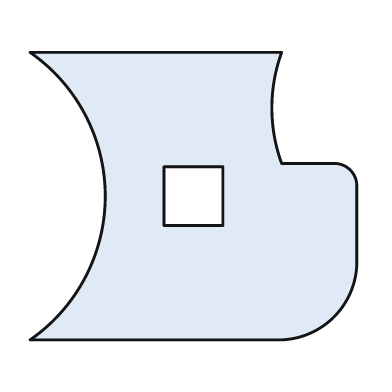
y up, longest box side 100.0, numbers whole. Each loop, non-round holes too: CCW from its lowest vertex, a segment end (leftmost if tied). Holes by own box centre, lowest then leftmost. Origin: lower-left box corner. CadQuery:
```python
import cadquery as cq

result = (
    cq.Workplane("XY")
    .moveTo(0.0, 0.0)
    .lineTo(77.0, 0.0)
    .threePointArc((93.0, 7.0), (100.0, 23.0))
    .lineTo(100.0, 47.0)
    .threePointArc((98.0, 52.0), (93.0, 54.0))
    .lineTo(77.0, 54.0)
    .threePointArc((74.0, 71.0), (77.0, 88.0))
    .lineTo(0.0, 88.0)
    .threePointArc((23.0, 44.0), (0.0, 0.0))
    .close()
    .moveTo(41.0, 35.0)
    .lineTo(59.0, 35.0)
    .lineTo(59.0, 53.0)
    .lineTo(41.0, 53.0)
    .close()
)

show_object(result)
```